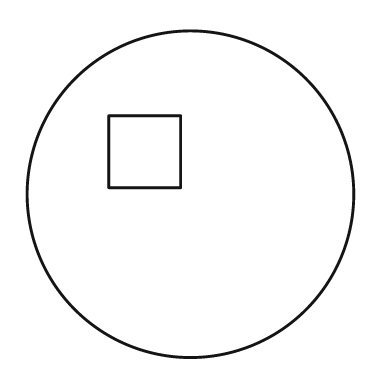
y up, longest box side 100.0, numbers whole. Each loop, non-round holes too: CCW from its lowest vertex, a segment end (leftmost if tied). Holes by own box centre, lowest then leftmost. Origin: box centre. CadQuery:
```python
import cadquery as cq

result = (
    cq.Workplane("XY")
    .moveTo(0.0, 0.0)
    .circle(50.0)
    .moveTo(-25.0, 2.0)
    .lineTo(-3.0, 2.0)
    .lineTo(-3.0, 24.0)
    .lineTo(-25.0, 24.0)
    .close()
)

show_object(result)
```